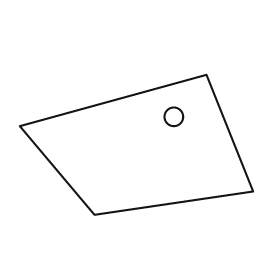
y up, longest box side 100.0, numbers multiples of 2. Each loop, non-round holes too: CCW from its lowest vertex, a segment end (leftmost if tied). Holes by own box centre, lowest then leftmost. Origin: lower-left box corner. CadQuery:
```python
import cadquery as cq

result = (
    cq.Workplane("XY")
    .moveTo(32.0, 0.0)
    .lineTo(100.0, 10.0)
    .lineTo(80.0, 60.0)
    .lineTo(0.0, 38.0)
    .close()
    .moveTo(66.0, 42.0)
    .circle(4.0)
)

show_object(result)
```